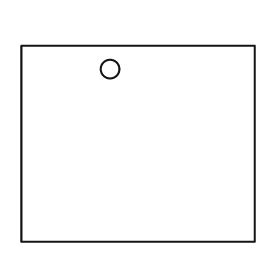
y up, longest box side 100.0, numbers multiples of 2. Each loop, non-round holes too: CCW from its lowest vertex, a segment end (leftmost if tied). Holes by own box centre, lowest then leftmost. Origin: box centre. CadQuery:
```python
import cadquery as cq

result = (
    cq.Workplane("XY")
    .moveTo(-50.0, -42.0)
    .lineTo(50.0, -42.0)
    .lineTo(50.0, 42.0)
    .lineTo(-50.0, 42.0)
    .close()
    .moveTo(-12.0, 32.0)
    .circle(4.0)
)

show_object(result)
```